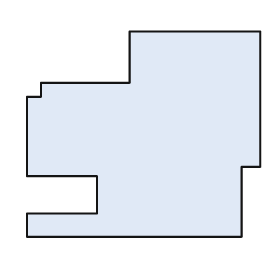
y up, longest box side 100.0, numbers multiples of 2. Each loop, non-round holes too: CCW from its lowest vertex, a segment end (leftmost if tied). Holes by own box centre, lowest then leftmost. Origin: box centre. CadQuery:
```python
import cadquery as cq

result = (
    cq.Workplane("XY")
    .moveTo(-50.0, -44.0)
    .lineTo(42.0, -44.0)
    .lineTo(42.0, -14.0)
    .lineTo(50.0, -14.0)
    .lineTo(50.0, 44.0)
    .lineTo(-6.0, 44.0)
    .lineTo(-6.0, 22.0)
    .lineTo(-44.0, 22.0)
    .lineTo(-44.0, 16.0)
    .lineTo(-50.0, 16.0)
    .lineTo(-50.0, -18.0)
    .lineTo(-20.0, -18.0)
    .lineTo(-20.0, -34.0)
    .lineTo(-50.0, -34.0)
    .close()
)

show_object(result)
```